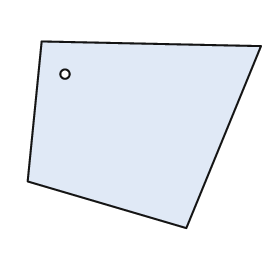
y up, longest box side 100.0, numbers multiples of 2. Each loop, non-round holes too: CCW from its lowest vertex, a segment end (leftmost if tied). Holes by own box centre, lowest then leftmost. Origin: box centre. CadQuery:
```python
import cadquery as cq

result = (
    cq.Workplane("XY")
    .moveTo(18.0, -40.0)
    .lineTo(50.0, 38.0)
    .lineTo(-44.0, 40.0)
    .lineTo(-50.0, -20.0)
    .close()
    .moveTo(-34.0, 26.0)
    .circle(2.0)
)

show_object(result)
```